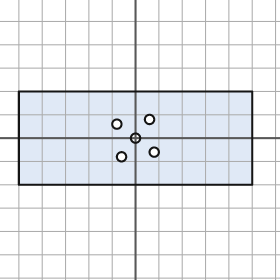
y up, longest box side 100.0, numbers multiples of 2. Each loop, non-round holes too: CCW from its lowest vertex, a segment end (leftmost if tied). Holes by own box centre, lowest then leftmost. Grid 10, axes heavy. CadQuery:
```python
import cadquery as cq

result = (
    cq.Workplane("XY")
    .moveTo(-50.0, -20.0)
    .lineTo(50.0, -20.0)
    .lineTo(50.0, 20.0)
    .lineTo(-50.0, 20.0)
    .close()
    .moveTo(-6.0, -8.0)
    .circle(2.0)
    .moveTo(8.0, -6.0)
    .circle(2.0)
    .moveTo(0.0, 0.0)
    .circle(2.0)
    .moveTo(-8.0, 6.0)
    .circle(2.0)
    .moveTo(6.0, 8.0)
    .circle(2.0)
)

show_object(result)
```